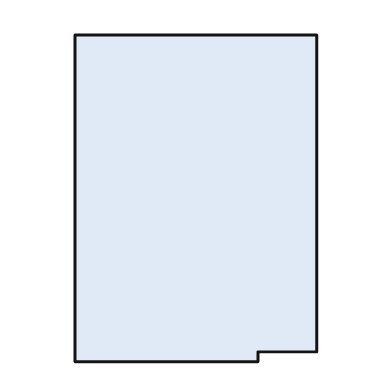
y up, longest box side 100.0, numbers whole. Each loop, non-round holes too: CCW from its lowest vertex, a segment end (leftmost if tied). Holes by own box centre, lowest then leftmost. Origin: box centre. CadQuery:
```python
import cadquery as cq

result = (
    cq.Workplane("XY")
    .moveTo(-37.0, -50.0)
    .lineTo(19.0, -50.0)
    .lineTo(19.0, -47.0)
    .lineTo(37.0, -47.0)
    .lineTo(37.0, 50.0)
    .lineTo(-37.0, 50.0)
    .close()
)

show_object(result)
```